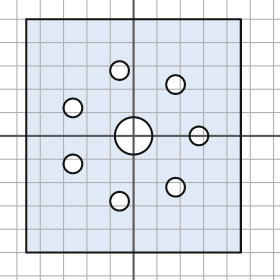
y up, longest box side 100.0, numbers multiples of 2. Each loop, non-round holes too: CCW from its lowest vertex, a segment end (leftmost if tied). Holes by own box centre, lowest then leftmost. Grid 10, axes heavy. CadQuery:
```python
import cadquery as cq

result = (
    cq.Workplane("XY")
    .moveTo(-46.0, -50.0)
    .lineTo(46.0, -50.0)
    .lineTo(46.0, 50.0)
    .lineTo(-46.0, 50.0)
    .close()
    .moveTo(-6.0, -28.0)
    .circle(4.0)
    .moveTo(18.0, -22.0)
    .circle(4.0)
    .moveTo(-26.0, -12.0)
    .circle(4.0)
    .moveTo(0.0, 0.0)
    .circle(8.0)
    .moveTo(28.0, 0.0)
    .circle(4.0)
    .moveTo(-26.0, 12.0)
    .circle(4.0)
    .moveTo(18.0, 22.0)
    .circle(4.0)
    .moveTo(-6.0, 28.0)
    .circle(4.0)
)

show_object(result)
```